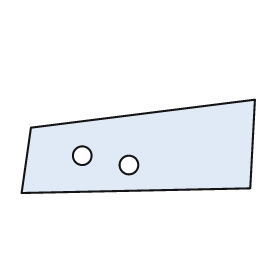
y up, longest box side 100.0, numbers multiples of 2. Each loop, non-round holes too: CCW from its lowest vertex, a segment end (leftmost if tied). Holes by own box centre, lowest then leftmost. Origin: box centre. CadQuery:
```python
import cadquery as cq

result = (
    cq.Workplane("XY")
    .moveTo(-50.0, -20.0)
    .lineTo(48.0, -18.0)
    .lineTo(50.0, 20.0)
    .lineTo(-46.0, 8.0)
    .close()
    .moveTo(-4.0, -8.0)
    .circle(4.0)
    .moveTo(-24.0, -4.0)
    .circle(4.0)
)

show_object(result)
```